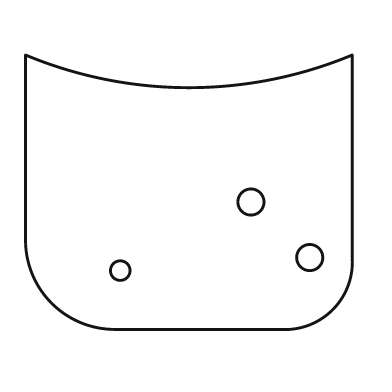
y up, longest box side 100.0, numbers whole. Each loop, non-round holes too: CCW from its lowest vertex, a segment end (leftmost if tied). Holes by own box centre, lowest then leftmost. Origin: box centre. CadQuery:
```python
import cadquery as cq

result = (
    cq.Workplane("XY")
    .moveTo(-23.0, -42.0)
    .lineTo(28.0, -42.0)
    .threePointArc((44.0, -36.0), (50.0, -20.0))
    .lineTo(50.0, 42.0)
    .threePointArc((0.0, 32.0), (-50.0, 42.0))
    .lineTo(-50.0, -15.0)
    .threePointArc((-42.0, -34.0), (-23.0, -42.0))
    .close()
    .moveTo(-21.0, -24.0)
    .circle(3.0)
    .moveTo(37.0, -20.0)
    .circle(4.0)
    .moveTo(19.0, -3.0)
    .circle(4.0)
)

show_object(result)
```